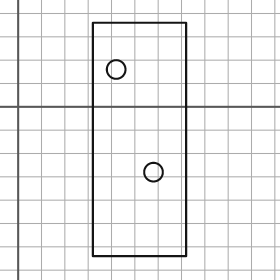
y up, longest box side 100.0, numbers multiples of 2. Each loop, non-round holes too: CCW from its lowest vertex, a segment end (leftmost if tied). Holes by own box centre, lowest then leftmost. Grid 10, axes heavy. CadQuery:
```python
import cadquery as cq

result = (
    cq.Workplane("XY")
    .moveTo(32.0, -64.0)
    .lineTo(72.0, -64.0)
    .lineTo(72.0, 36.0)
    .lineTo(32.0, 36.0)
    .close()
    .moveTo(58.0, -28.0)
    .circle(4.0)
    .moveTo(42.0, 16.0)
    .circle(4.0)
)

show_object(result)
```